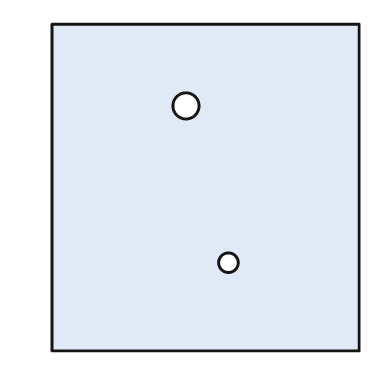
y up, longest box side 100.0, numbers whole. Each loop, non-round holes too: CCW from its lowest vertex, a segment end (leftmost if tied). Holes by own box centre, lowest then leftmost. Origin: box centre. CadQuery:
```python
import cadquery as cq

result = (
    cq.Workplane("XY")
    .moveTo(-47.0, -50.0)
    .lineTo(47.0, -50.0)
    .lineTo(47.0, 50.0)
    .lineTo(-47.0, 50.0)
    .close()
    .moveTo(7.0, -23.0)
    .circle(3.0)
    .moveTo(-6.0, 25.0)
    .circle(4.0)
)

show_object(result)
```